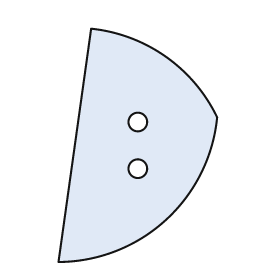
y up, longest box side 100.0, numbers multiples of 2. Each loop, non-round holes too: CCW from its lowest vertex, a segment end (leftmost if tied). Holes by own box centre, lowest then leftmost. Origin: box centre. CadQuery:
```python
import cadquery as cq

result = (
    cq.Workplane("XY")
    .moveTo(-34.0, -50.0)
    .threePointArc((12.0, -32.0), (34.0, 12.0))
    .threePointArc((12.0, 38.0), (-20.0, 50.0))
    .close()
    .moveTo(0.0, -10.0)
    .circle(4.0)
    .moveTo(0.0, 10.0)
    .circle(4.0)
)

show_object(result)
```